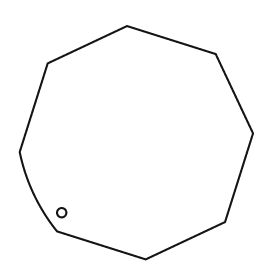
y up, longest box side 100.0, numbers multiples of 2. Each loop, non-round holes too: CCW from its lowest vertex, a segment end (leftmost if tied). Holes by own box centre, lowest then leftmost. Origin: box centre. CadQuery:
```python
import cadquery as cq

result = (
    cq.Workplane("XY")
    .moveTo(4.0, -50.0)
    .lineTo(38.0, -34.0)
    .lineTo(50.0, 4.0)
    .lineTo(34.0, 38.0)
    .lineTo(-4.0, 50.0)
    .lineTo(-38.0, 34.0)
    .lineTo(-50.0, -4.0)
    .threePointArc((-44.0, -22.0), (-34.0, -38.0))
    .close()
    .moveTo(-32.0, -30.0)
    .circle(2.0)
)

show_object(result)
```